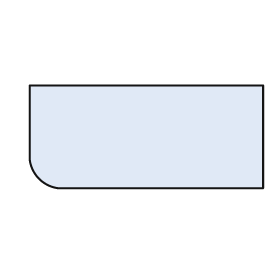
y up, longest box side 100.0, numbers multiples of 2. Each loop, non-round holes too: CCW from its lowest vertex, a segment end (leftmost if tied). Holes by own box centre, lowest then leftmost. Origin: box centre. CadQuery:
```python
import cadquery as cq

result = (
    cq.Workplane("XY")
    .moveTo(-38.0, -22.0)
    .lineTo(50.0, -22.0)
    .lineTo(50.0, 22.0)
    .lineTo(-50.0, 22.0)
    .lineTo(-50.0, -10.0)
    .threePointArc((-46.0, -18.0), (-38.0, -22.0))
    .close()
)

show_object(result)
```